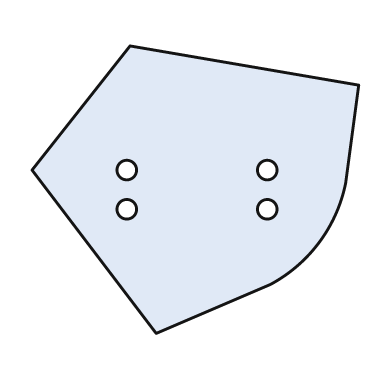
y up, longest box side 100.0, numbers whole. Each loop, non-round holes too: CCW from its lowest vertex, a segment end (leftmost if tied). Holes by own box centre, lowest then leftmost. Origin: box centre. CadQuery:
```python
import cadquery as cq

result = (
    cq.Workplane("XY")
    .moveTo(-12.0, -44.0)
    .lineTo(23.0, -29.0)
    .threePointArc((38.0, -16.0), (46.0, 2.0))
    .lineTo(50.0, 32.0)
    .lineTo(-20.0, 44.0)
    .lineTo(-50.0, 6.0)
    .close()
    .moveTo(-21.0, -6.0)
    .circle(3.0)
    .moveTo(22.0, -6.0)
    .circle(3.0)
    .moveTo(-21.0, 6.0)
    .circle(3.0)
    .moveTo(22.0, 6.0)
    .circle(3.0)
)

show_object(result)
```